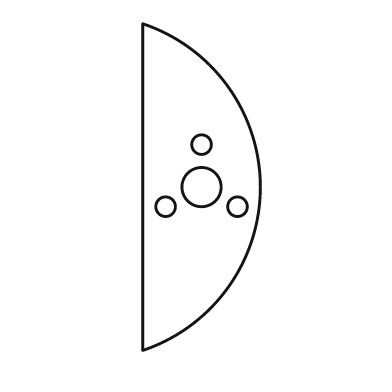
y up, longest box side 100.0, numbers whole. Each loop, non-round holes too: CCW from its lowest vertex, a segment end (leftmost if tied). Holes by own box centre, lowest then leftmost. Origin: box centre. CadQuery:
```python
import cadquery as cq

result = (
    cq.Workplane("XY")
    .moveTo(-18.0, -50.0)
    .threePointArc((18.0, 0.0), (-18.0, 50.0))
    .close()
    .moveTo(-11.0, -6.0)
    .circle(3.0)
    .moveTo(11.0, -6.0)
    .circle(3.0)
    .moveTo(0.0, 0.0)
    .circle(6.0)
    .moveTo(0.0, 13.0)
    .circle(3.0)
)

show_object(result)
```